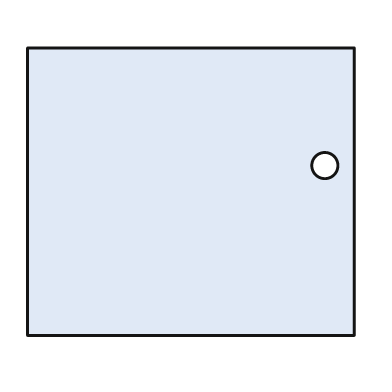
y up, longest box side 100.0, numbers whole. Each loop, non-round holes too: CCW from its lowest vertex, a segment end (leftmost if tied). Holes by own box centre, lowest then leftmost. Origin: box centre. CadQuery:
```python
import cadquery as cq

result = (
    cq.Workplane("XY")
    .moveTo(-50.0, -44.0)
    .lineTo(50.0, -44.0)
    .lineTo(50.0, 44.0)
    .lineTo(-50.0, 44.0)
    .close()
    .moveTo(41.0, 8.0)
    .circle(4.0)
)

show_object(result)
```